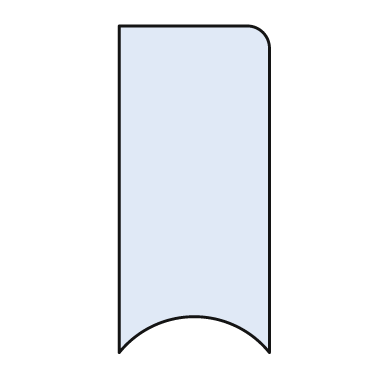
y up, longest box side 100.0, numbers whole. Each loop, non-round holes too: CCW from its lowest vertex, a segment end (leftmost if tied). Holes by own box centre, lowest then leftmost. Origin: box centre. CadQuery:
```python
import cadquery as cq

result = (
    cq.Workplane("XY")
    .moveTo(-23.0, -50.0)
    .threePointArc((0.0, -39.0), (23.0, -50.0))
    .lineTo(23.0, 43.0)
    .threePointArc((21.0, 48.0), (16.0, 50.0))
    .lineTo(-23.0, 50.0)
    .close()
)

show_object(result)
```